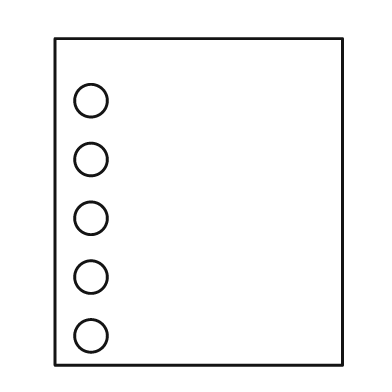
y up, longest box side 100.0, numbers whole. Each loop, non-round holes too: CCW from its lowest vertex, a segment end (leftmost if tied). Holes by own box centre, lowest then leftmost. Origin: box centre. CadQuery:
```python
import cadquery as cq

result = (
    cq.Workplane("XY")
    .moveTo(-44.0, -50.0)
    .lineTo(44.0, -50.0)
    .lineTo(44.0, 50.0)
    .lineTo(-44.0, 50.0)
    .close()
    .moveTo(-33.0, -41.0)
    .circle(5.0)
    .moveTo(-33.0, -23.0)
    .circle(5.0)
    .moveTo(-33.0, -5.0)
    .circle(5.0)
    .moveTo(-33.0, 13.0)
    .circle(5.0)
    .moveTo(-33.0, 31.0)
    .circle(5.0)
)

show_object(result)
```